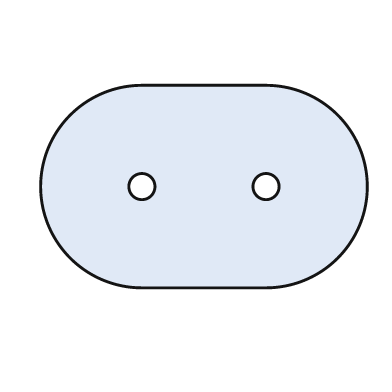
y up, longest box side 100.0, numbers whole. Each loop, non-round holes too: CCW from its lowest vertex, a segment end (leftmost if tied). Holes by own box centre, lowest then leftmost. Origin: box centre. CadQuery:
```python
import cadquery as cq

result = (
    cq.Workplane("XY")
    .moveTo(-19.0, -31.0)
    .lineTo(19.0, -31.0)
    .threePointArc((50.0, 0.0), (19.0, 31.0))
    .lineTo(-19.0, 31.0)
    .threePointArc((-50.0, 0.0), (-19.0, -31.0))
    .close()
    .moveTo(-19.0, 0.0)
    .circle(4.0)
    .moveTo(19.0, 0.0)
    .circle(4.0)
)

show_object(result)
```